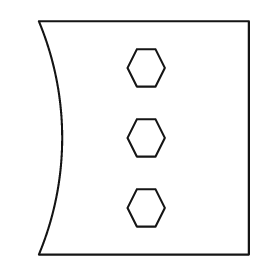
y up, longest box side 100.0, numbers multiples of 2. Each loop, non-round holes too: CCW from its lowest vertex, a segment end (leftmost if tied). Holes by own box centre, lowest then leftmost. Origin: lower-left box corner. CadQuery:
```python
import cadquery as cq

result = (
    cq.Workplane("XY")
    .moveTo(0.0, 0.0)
    .lineTo(90.0, 0.0)
    .lineTo(90.0, 100.0)
    .lineTo(0.0, 100.0)
    .threePointArc((10.0, 50.0), (0.0, 0.0))
    .close()
    .moveTo(42.0, 12.0)
    .lineTo(50.0, 12.0)
    .lineTo(54.0, 20.0)
    .lineTo(50.0, 28.0)
    .lineTo(42.0, 28.0)
    .lineTo(38.0, 20.0)
    .close()
    .moveTo(42.0, 42.0)
    .lineTo(50.0, 42.0)
    .lineTo(54.0, 50.0)
    .lineTo(50.0, 58.0)
    .lineTo(42.0, 58.0)
    .lineTo(38.0, 50.0)
    .close()
    .moveTo(42.0, 72.0)
    .lineTo(50.0, 72.0)
    .lineTo(54.0, 80.0)
    .lineTo(50.0, 88.0)
    .lineTo(42.0, 88.0)
    .lineTo(38.0, 80.0)
    .close()
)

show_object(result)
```